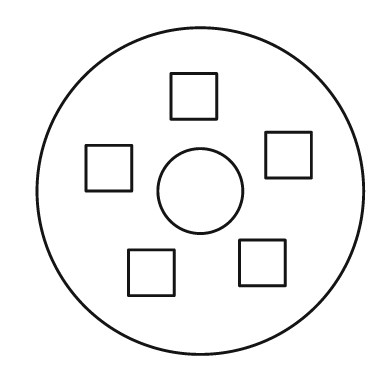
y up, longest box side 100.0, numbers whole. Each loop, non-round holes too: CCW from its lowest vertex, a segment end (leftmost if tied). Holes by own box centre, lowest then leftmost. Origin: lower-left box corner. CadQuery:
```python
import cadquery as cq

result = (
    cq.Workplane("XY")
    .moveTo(50.0, 50.0)
    .circle(50.0)
    .moveTo(28.0, 18.0)
    .lineTo(42.0, 18.0)
    .lineTo(42.0, 32.0)
    .lineTo(28.0, 32.0)
    .close()
    .moveTo(62.0, 21.0)
    .lineTo(76.0, 21.0)
    .lineTo(76.0, 35.0)
    .lineTo(62.0, 35.0)
    .close()
    .moveTo(50.0, 50.0)
    .circle(13.0)
    .moveTo(15.0, 50.0)
    .lineTo(29.0, 50.0)
    .lineTo(29.0, 64.0)
    .lineTo(15.0, 64.0)
    .close()
    .moveTo(70.0, 54.0)
    .lineTo(84.0, 54.0)
    .lineTo(84.0, 68.0)
    .lineTo(70.0, 68.0)
    .close()
    .moveTo(41.0, 72.0)
    .lineTo(55.0, 72.0)
    .lineTo(55.0, 86.0)
    .lineTo(41.0, 86.0)
    .close()
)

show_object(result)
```